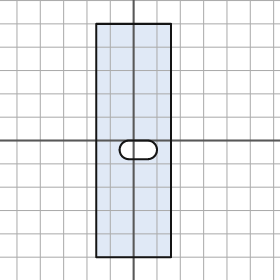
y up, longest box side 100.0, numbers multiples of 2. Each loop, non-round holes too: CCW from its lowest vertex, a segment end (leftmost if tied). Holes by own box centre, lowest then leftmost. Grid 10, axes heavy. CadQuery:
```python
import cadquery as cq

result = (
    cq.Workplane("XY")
    .moveTo(-16.0, -50.0)
    .lineTo(16.0, -50.0)
    .lineTo(16.0, 50.0)
    .lineTo(-16.0, 50.0)
    .close()
    .moveTo(-2.0, -8.0)
    .lineTo(6.0, -8.0)
    .threePointArc((10.0, -4.0), (6.0, 0.0))
    .lineTo(-2.0, 0.0)
    .threePointArc((-6.0, -4.0), (-2.0, -8.0))
    .close()
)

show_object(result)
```